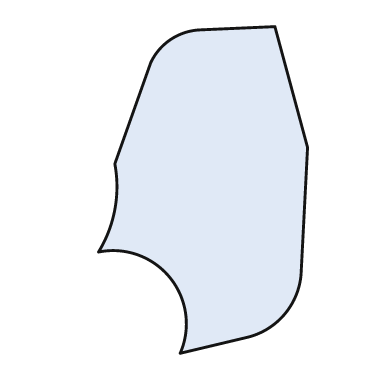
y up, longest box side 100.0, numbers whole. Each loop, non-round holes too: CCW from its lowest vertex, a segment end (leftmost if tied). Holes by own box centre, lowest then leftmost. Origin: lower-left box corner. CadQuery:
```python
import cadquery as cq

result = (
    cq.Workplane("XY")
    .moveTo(25.0, 0.0)
    .lineTo(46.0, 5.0)
    .threePointArc((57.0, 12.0), (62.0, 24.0))
    .lineTo(64.0, 63.0)
    .lineTo(54.0, 100.0)
    .lineTo(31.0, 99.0)
    .threePointArc((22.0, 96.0), (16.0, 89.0))
    .lineTo(5.0, 58.0)
    .threePointArc((5.0, 44.0), (0.0, 31.0))
    .threePointArc((22.0, 23.0), (25.0, 0.0))
    .close()
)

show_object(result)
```